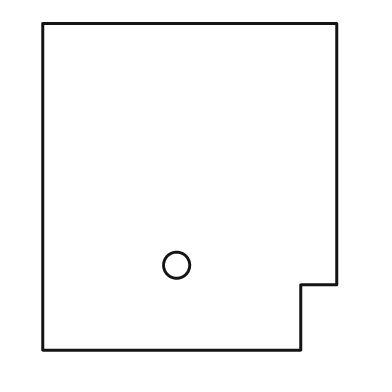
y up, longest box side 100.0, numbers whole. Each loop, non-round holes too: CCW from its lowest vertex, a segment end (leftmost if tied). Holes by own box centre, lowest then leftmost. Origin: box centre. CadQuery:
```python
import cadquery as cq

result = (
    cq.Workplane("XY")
    .moveTo(-45.0, -50.0)
    .lineTo(34.0, -50.0)
    .lineTo(34.0, -30.0)
    .lineTo(45.0, -30.0)
    .lineTo(45.0, 50.0)
    .lineTo(-45.0, 50.0)
    .close()
    .moveTo(-4.0, -24.0)
    .circle(4.0)
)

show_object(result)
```